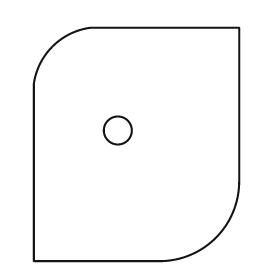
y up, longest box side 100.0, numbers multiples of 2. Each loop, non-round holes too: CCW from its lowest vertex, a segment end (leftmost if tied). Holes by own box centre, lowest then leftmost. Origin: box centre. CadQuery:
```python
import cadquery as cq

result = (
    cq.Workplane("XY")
    .moveTo(-44.0, -50.0)
    .lineTo(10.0, -50.0)
    .threePointArc((34.0, -40.0), (44.0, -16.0))
    .lineTo(44.0, 50.0)
    .lineTo(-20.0, 50.0)
    .threePointArc((-36.0, 42.0), (-44.0, 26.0))
    .close()
    .moveTo(-8.0, 6.0)
    .circle(6.0)
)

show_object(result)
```